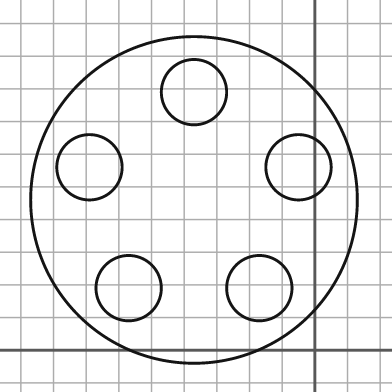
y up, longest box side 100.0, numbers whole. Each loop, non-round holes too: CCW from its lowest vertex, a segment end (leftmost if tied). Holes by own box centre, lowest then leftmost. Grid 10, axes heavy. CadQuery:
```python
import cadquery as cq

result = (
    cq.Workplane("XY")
    .moveTo(-37.0, 46.0)
    .circle(50.0)
    .moveTo(-57.0, 19.0)
    .circle(10.0)
    .moveTo(-17.0, 19.0)
    .circle(10.0)
    .moveTo(-69.0, 56.0)
    .circle(10.0)
    .moveTo(-5.0, 56.0)
    .circle(10.0)
    .moveTo(-37.0, 79.0)
    .circle(10.0)
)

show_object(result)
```